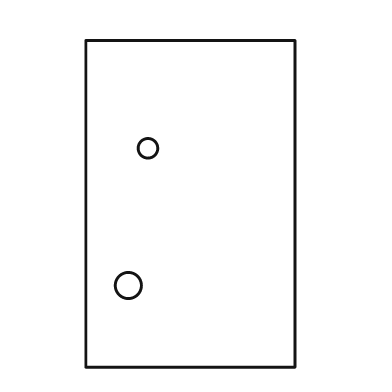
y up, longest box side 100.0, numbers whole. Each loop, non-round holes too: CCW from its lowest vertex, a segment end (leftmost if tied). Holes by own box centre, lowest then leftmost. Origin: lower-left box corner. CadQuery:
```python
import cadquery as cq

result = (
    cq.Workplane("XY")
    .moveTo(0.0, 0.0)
    .lineTo(64.0, 0.0)
    .lineTo(64.0, 100.0)
    .lineTo(0.0, 100.0)
    .close()
    .moveTo(13.0, 25.0)
    .circle(4.0)
    .moveTo(19.0, 67.0)
    .circle(3.0)
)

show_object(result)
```